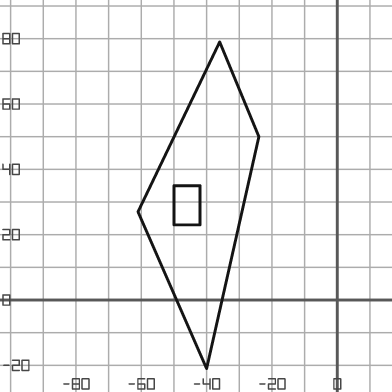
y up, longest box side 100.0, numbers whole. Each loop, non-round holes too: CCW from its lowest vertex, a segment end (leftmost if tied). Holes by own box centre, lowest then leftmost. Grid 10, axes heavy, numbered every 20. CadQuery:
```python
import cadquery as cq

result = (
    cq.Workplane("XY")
    .moveTo(-40.0, -21.0)
    .lineTo(-24.0, 50.0)
    .lineTo(-36.0, 79.0)
    .lineTo(-61.0, 27.0)
    .close()
    .moveTo(-50.0, 23.0)
    .lineTo(-42.0, 23.0)
    .lineTo(-42.0, 35.0)
    .lineTo(-50.0, 35.0)
    .close()
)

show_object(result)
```